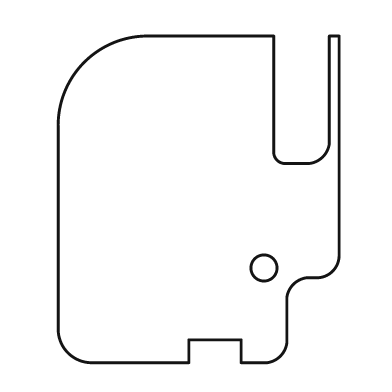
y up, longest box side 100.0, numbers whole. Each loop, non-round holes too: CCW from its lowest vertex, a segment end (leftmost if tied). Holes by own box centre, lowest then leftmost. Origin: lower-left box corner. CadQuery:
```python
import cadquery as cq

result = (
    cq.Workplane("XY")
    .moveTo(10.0, 0.0)
    .lineTo(40.0, 0.0)
    .lineTo(40.0, 7.0)
    .lineTo(56.0, 7.0)
    .lineTo(56.0, 0.0)
    .lineTo(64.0, 0.0)
    .threePointArc((68.0, 2.0), (70.0, 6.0))
    .lineTo(70.0, 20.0)
    .threePointArc((72.0, 24.0), (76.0, 26.0))
    .lineTo(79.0, 26.0)
    .threePointArc((84.0, 28.0), (86.0, 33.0))
    .lineTo(86.0, 100.0)
    .lineTo(83.0, 100.0)
    .lineTo(83.0, 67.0)
    .threePointArc((81.0, 63.0), (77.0, 61.0))
    .lineTo(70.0, 61.0)
    .threePointArc((67.0, 62.0), (66.0, 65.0))
    .lineTo(66.0, 100.0)
    .lineTo(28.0, 100.0)
    .threePointArc((8.0, 92.0), (0.0, 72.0))
    .lineTo(0.0, 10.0)
    .threePointArc((3.0, 3.0), (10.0, 0.0))
    .close()
    .moveTo(63.0, 29.0)
    .circle(4.0)
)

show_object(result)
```